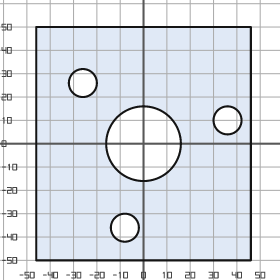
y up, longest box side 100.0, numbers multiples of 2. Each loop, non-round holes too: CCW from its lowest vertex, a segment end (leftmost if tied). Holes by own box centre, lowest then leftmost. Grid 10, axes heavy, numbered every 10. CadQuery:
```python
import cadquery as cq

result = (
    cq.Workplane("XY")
    .moveTo(-46.0, -50.0)
    .lineTo(46.0, -50.0)
    .lineTo(46.0, 50.0)
    .lineTo(-46.0, 50.0)
    .close()
    .moveTo(-8.0, -36.0)
    .circle(6.0)
    .moveTo(0.0, 0.0)
    .circle(16.0)
    .moveTo(36.0, 10.0)
    .circle(6.0)
    .moveTo(-26.0, 26.0)
    .circle(6.0)
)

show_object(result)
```